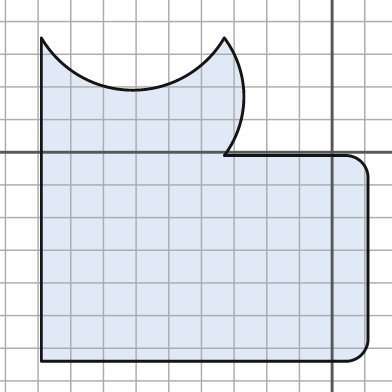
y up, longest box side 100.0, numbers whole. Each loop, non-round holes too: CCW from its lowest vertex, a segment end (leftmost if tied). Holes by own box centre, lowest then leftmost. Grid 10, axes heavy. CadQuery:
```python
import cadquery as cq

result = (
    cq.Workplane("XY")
    .moveTo(-89.0, -64.0)
    .lineTo(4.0, -64.0)
    .threePointArc((9.0, -62.0), (11.0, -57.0))
    .lineTo(11.0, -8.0)
    .threePointArc((9.0, -3.0), (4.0, -1.0))
    .lineTo(-33.0, -1.0)
    .threePointArc((-27.0, 17.0), (-33.0, 35.0))
    .threePointArc((-61.0, 19.0), (-89.0, 35.0))
    .close()
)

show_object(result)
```